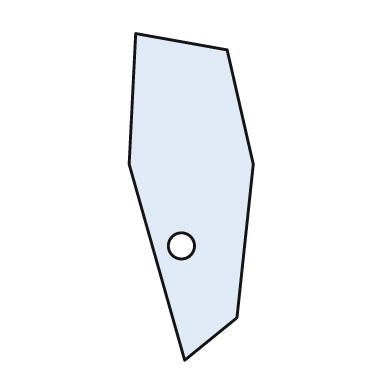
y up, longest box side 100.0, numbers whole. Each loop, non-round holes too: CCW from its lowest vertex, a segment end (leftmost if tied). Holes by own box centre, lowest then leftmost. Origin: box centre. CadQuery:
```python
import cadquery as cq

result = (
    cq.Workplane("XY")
    .moveTo(-2.0, -50.0)
    .lineTo(14.0, -37.0)
    .lineTo(19.0, 10.0)
    .lineTo(11.0, 45.0)
    .lineTo(-17.0, 50.0)
    .lineTo(-19.0, 10.0)
    .close()
    .moveTo(-3.0, -15.0)
    .circle(4.0)
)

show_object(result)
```